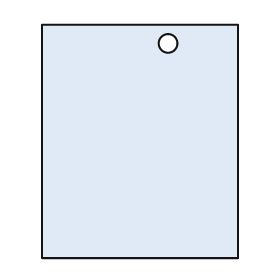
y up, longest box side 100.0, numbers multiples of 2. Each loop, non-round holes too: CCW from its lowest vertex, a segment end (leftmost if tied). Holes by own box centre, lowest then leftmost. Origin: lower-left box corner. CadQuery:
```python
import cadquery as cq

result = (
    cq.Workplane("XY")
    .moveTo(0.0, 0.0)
    .lineTo(84.0, 0.0)
    .lineTo(84.0, 100.0)
    .lineTo(0.0, 100.0)
    .close()
    .moveTo(54.0, 92.0)
    .circle(4.0)
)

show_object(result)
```